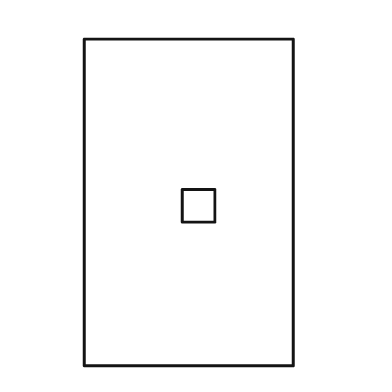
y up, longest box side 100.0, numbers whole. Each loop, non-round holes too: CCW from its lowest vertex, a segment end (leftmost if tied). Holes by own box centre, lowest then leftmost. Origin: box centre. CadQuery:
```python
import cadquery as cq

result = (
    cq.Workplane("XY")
    .moveTo(-32.0, -50.0)
    .lineTo(32.0, -50.0)
    .lineTo(32.0, 50.0)
    .lineTo(-32.0, 50.0)
    .close()
    .moveTo(-2.0, -6.0)
    .lineTo(8.0, -6.0)
    .lineTo(8.0, 4.0)
    .lineTo(-2.0, 4.0)
    .close()
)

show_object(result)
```